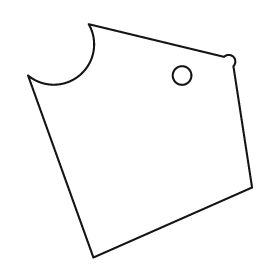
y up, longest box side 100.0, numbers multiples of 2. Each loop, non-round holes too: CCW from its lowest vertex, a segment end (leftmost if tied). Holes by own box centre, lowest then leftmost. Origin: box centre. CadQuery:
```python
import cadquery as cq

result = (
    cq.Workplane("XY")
    .moveTo(-20.0, -50.0)
    .lineTo(48.0, -20.0)
    .lineTo(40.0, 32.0)
    .threePointArc((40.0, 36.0), (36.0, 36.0))
    .lineTo(-22.0, 50.0)
    .threePointArc((-26.0, 28.0), (-48.0, 28.0))
    .close()
    .moveTo(18.0, 28.0)
    .circle(4.0)
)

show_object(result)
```